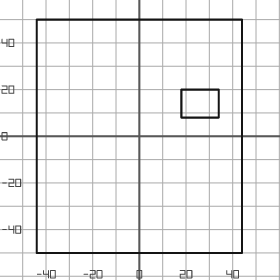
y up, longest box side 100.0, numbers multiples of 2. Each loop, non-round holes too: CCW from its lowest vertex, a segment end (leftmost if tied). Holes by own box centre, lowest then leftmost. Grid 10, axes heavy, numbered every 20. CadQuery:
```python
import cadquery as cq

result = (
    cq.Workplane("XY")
    .moveTo(-44.0, -50.0)
    .lineTo(44.0, -50.0)
    .lineTo(44.0, 50.0)
    .lineTo(-44.0, 50.0)
    .close()
    .moveTo(18.0, 8.0)
    .lineTo(34.0, 8.0)
    .lineTo(34.0, 20.0)
    .lineTo(18.0, 20.0)
    .close()
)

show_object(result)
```